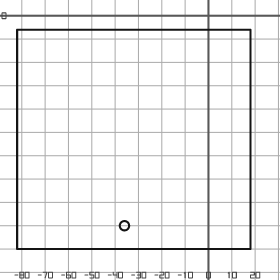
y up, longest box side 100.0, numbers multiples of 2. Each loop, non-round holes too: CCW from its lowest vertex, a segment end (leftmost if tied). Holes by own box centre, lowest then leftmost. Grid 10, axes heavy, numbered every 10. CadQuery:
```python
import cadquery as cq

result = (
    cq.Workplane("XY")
    .moveTo(-82.0, -100.0)
    .lineTo(18.0, -100.0)
    .lineTo(18.0, -6.0)
    .lineTo(-82.0, -6.0)
    .close()
    .moveTo(-36.0, -90.0)
    .circle(2.0)
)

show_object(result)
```